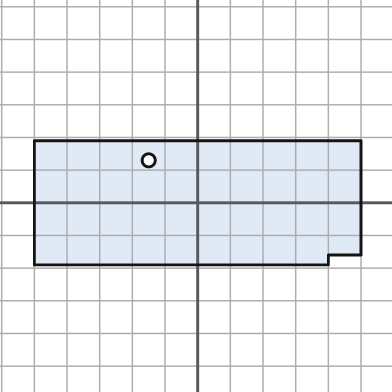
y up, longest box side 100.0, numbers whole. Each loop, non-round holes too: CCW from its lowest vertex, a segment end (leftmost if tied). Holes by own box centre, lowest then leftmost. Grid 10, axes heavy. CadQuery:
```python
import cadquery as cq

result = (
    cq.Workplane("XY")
    .moveTo(-50.0, -19.0)
    .lineTo(40.0, -19.0)
    .lineTo(40.0, -16.0)
    .lineTo(50.0, -16.0)
    .lineTo(50.0, 19.0)
    .lineTo(-50.0, 19.0)
    .close()
    .moveTo(-15.0, 13.0)
    .circle(2.0)
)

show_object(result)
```